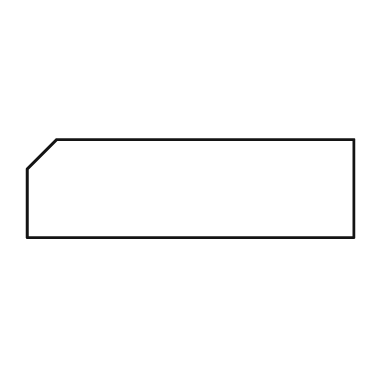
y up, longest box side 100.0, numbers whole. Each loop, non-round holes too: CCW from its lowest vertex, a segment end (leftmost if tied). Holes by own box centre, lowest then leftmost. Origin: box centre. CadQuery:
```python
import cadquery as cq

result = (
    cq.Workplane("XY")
    .moveTo(-50.0, -15.0)
    .lineTo(50.0, -15.0)
    .lineTo(50.0, 15.0)
    .lineTo(-41.0, 15.0)
    .lineTo(-50.0, 6.0)
    .close()
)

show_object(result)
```